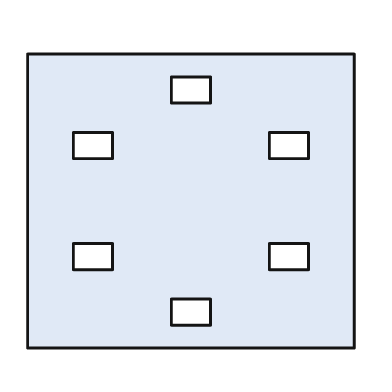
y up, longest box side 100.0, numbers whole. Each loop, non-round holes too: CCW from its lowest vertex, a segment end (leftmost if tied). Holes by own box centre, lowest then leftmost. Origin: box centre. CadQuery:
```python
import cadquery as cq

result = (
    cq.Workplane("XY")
    .moveTo(-50.0, -45.0)
    .lineTo(50.0, -45.0)
    .lineTo(50.0, 45.0)
    .lineTo(-50.0, 45.0)
    .close()
    .moveTo(-6.0, -38.0)
    .lineTo(6.0, -38.0)
    .lineTo(6.0, -30.0)
    .lineTo(-6.0, -30.0)
    .close()
    .moveTo(-36.0, -21.0)
    .lineTo(-24.0, -21.0)
    .lineTo(-24.0, -13.0)
    .lineTo(-36.0, -13.0)
    .close()
    .moveTo(24.0, -21.0)
    .lineTo(36.0, -21.0)
    .lineTo(36.0, -13.0)
    .lineTo(24.0, -13.0)
    .close()
    .moveTo(-36.0, 13.0)
    .lineTo(-24.0, 13.0)
    .lineTo(-24.0, 21.0)
    .lineTo(-36.0, 21.0)
    .close()
    .moveTo(24.0, 13.0)
    .lineTo(36.0, 13.0)
    .lineTo(36.0, 21.0)
    .lineTo(24.0, 21.0)
    .close()
    .moveTo(-6.0, 30.0)
    .lineTo(6.0, 30.0)
    .lineTo(6.0, 38.0)
    .lineTo(-6.0, 38.0)
    .close()
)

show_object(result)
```